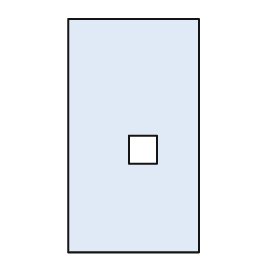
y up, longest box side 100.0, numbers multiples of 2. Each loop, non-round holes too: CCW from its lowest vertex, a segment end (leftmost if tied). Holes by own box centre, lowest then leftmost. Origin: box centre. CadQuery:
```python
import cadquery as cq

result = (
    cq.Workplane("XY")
    .moveTo(-28.0, -50.0)
    .lineTo(28.0, -50.0)
    .lineTo(28.0, 50.0)
    .lineTo(-28.0, 50.0)
    .close()
    .moveTo(-2.0, -12.0)
    .lineTo(10.0, -12.0)
    .lineTo(10.0, 0.0)
    .lineTo(-2.0, 0.0)
    .close()
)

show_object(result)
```